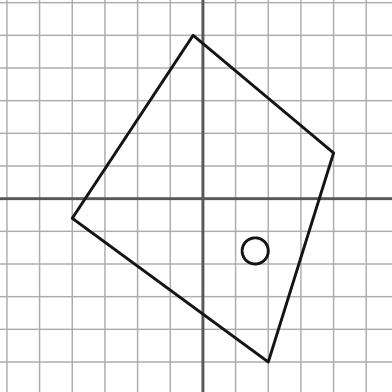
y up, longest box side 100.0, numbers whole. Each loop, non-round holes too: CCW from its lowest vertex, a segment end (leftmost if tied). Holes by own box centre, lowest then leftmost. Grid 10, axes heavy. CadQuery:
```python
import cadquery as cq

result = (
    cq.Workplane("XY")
    .moveTo(20.0, -50.0)
    .lineTo(40.0, 14.0)
    .lineTo(-3.0, 50.0)
    .lineTo(-40.0, -6.0)
    .close()
    .moveTo(16.0, -16.0)
    .circle(4.0)
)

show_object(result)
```